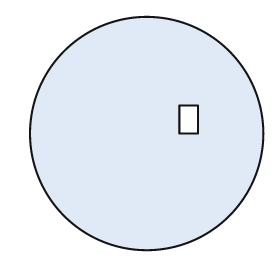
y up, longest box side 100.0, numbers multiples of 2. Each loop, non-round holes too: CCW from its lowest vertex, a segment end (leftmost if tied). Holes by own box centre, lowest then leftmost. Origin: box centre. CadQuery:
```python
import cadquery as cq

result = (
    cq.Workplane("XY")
    .moveTo(0.0, 0.0)
    .circle(50.0)
    .moveTo(14.0, 0.0)
    .lineTo(22.0, 0.0)
    .lineTo(22.0, 12.0)
    .lineTo(14.0, 12.0)
    .close()
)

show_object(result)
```